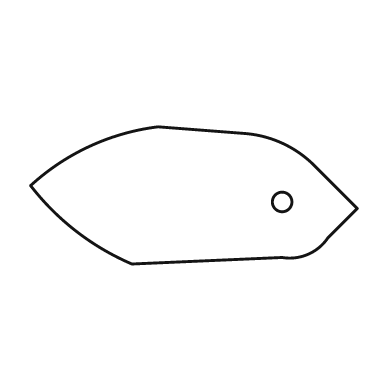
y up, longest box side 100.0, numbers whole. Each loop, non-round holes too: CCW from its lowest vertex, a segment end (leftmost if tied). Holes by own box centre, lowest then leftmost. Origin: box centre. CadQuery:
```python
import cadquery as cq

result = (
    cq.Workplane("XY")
    .moveTo(-19.0, -21.0)
    .lineTo(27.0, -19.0)
    .threePointArc((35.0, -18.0), (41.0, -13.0))
    .lineTo(50.0, -4.0)
    .lineTo(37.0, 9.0)
    .threePointArc((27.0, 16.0), (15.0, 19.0))
    .lineTo(-11.0, 21.0)
    .threePointArc((-32.0, 15.0), (-50.0, 3.0))
    .threePointArc((-36.0, -11.0), (-19.0, -21.0))
    .close()
    .moveTo(27.0, -2.0)
    .circle(3.0)
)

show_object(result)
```